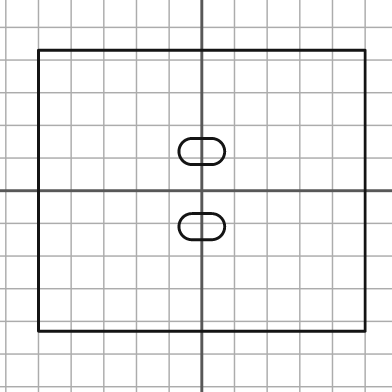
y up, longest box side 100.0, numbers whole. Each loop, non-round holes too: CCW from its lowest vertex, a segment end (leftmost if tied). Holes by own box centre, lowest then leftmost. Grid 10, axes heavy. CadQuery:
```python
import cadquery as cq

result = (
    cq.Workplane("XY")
    .moveTo(-50.0, -43.0)
    .lineTo(50.0, -43.0)
    .lineTo(50.0, 43.0)
    .lineTo(-50.0, 43.0)
    .close()
    .moveTo(-3.0, -15.0)
    .lineTo(3.0, -15.0)
    .threePointArc((7.0, -11.0), (3.0, -7.0))
    .lineTo(-3.0, -7.0)
    .threePointArc((-7.0, -11.0), (-3.0, -15.0))
    .close()
    .moveTo(-3.0, 8.0)
    .lineTo(3.0, 8.0)
    .threePointArc((7.0, 12.0), (3.0, 16.0))
    .lineTo(-3.0, 16.0)
    .threePointArc((-7.0, 12.0), (-3.0, 8.0))
    .close()
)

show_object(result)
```